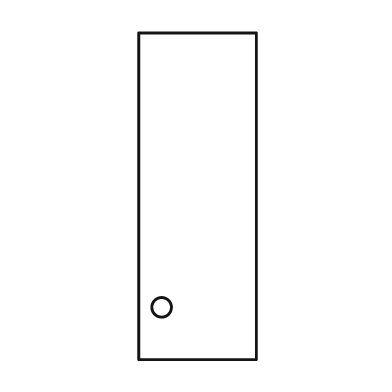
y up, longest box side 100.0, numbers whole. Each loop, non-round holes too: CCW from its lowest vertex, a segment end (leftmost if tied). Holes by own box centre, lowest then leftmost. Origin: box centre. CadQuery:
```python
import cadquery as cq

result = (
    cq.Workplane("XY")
    .moveTo(-18.0, -50.0)
    .lineTo(18.0, -50.0)
    .lineTo(18.0, 50.0)
    .lineTo(-18.0, 50.0)
    .close()
    .moveTo(-11.0, -34.0)
    .circle(3.0)
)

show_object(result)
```